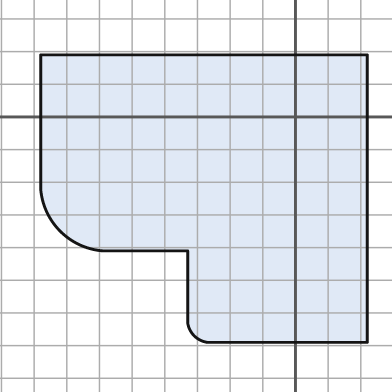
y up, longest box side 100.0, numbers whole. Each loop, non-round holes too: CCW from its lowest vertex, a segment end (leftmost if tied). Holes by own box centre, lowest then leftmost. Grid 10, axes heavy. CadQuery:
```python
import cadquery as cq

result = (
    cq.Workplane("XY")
    .moveTo(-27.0, -69.0)
    .lineTo(22.0, -69.0)
    .lineTo(22.0, 19.0)
    .lineTo(-78.0, 19.0)
    .lineTo(-78.0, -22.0)
    .threePointArc((-72.0, -35.0), (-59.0, -41.0))
    .lineTo(-33.0, -41.0)
    .lineTo(-33.0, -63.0)
    .threePointArc((-31.0, -67.0), (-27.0, -69.0))
    .close()
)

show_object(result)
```